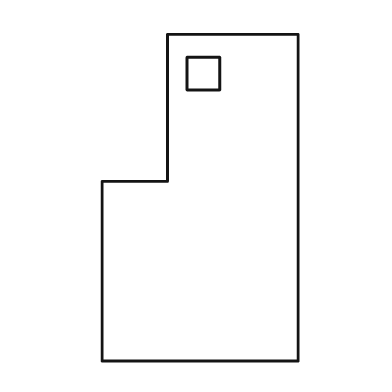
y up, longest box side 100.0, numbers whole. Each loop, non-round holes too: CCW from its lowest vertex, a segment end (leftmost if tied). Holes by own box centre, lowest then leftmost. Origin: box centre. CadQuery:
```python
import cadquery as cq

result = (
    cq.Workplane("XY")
    .moveTo(-30.0, -50.0)
    .lineTo(30.0, -50.0)
    .lineTo(30.0, 50.0)
    .lineTo(-10.0, 50.0)
    .lineTo(-10.0, 5.0)
    .lineTo(-30.0, 5.0)
    .close()
    .moveTo(-4.0, 33.0)
    .lineTo(6.0, 33.0)
    .lineTo(6.0, 43.0)
    .lineTo(-4.0, 43.0)
    .close()
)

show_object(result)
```